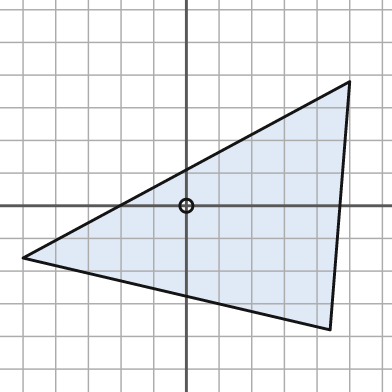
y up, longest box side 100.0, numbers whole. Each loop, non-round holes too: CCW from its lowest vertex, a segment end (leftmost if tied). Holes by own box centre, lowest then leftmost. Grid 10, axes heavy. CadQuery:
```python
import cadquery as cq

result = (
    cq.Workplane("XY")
    .moveTo(44.0, -38.0)
    .lineTo(50.0, 38.0)
    .lineTo(-50.0, -16.0)
    .close()
    .moveTo(0.0, 0.0)
    .circle(2.0)
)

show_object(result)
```